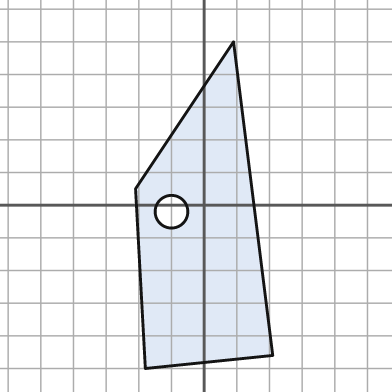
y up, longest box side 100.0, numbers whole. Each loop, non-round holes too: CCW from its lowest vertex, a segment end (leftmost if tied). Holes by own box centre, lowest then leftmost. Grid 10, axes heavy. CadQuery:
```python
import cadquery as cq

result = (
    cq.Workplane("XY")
    .moveTo(-18.0, -50.0)
    .lineTo(21.0, -46.0)
    .lineTo(9.0, 50.0)
    .lineTo(-21.0, 5.0)
    .close()
    .moveTo(-10.0, -2.0)
    .circle(5.0)
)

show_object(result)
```